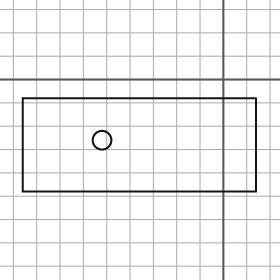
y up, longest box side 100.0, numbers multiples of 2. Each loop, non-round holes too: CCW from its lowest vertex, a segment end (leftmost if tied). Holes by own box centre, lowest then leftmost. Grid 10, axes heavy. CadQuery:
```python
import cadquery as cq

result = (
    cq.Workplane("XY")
    .moveTo(-86.0, -48.0)
    .lineTo(14.0, -48.0)
    .lineTo(14.0, -8.0)
    .lineTo(-86.0, -8.0)
    .close()
    .moveTo(-52.0, -26.0)
    .circle(4.0)
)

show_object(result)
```